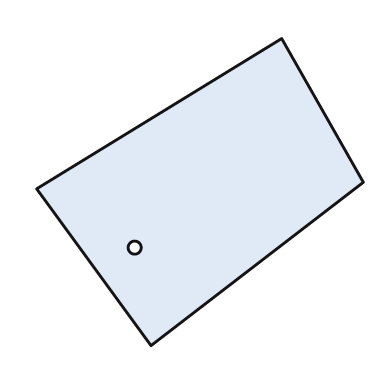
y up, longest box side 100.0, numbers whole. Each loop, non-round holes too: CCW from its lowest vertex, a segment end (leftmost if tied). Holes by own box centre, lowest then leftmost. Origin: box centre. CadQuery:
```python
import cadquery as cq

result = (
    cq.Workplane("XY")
    .moveTo(-15.0, -47.0)
    .lineTo(50.0, 3.0)
    .lineTo(25.0, 47.0)
    .lineTo(-50.0, 1.0)
    .close()
    .moveTo(-20.0, -17.0)
    .circle(2.0)
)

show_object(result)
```